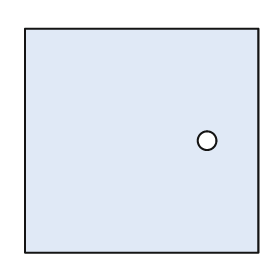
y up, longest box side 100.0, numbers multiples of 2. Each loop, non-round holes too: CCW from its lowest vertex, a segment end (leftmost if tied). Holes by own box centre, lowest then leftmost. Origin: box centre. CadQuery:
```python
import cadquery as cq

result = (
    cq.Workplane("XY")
    .moveTo(-50.0, -48.0)
    .lineTo(50.0, -48.0)
    .lineTo(50.0, 48.0)
    .lineTo(-50.0, 48.0)
    .close()
    .moveTo(28.0, 0.0)
    .circle(4.0)
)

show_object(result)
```